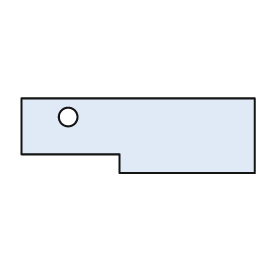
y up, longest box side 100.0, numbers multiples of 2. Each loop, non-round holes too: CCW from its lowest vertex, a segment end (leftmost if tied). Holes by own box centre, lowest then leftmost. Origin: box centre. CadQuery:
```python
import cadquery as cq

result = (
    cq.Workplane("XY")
    .moveTo(-8.0, -16.0)
    .lineTo(50.0, -16.0)
    .lineTo(50.0, 16.0)
    .lineTo(-50.0, 16.0)
    .lineTo(-50.0, -8.0)
    .lineTo(-8.0, -8.0)
    .close()
    .moveTo(-30.0, 8.0)
    .circle(4.0)
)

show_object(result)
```